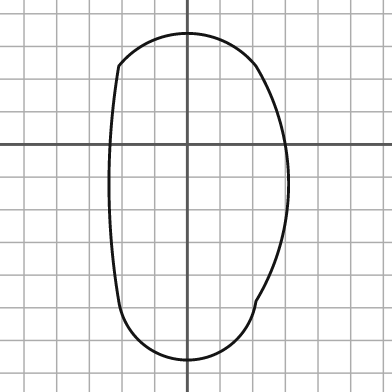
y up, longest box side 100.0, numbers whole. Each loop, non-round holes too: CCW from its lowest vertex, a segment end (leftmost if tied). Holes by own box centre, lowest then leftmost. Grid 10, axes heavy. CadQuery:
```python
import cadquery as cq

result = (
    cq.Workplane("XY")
    .moveTo(-21.0, -48.0)
    .threePointArc((0.0, -66.0), (21.0, -48.0))
    .threePointArc((31.0, -12.0), (21.0, 24.0))
    .threePointArc((0.0, 34.0), (-21.0, 24.0))
    .threePointArc((-24.0, -12.0), (-21.0, -48.0))
    .close()
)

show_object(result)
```